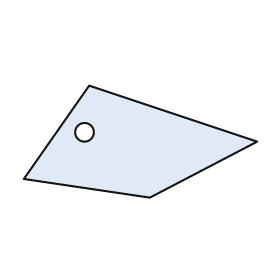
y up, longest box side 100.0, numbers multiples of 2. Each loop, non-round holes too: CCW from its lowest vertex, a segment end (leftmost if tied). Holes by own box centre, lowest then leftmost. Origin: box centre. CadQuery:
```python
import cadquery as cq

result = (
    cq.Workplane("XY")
    .moveTo(4.0, -24.0)
    .lineTo(50.0, 0.0)
    .lineTo(-22.0, 24.0)
    .lineTo(-50.0, -16.0)
    .close()
    .moveTo(-24.0, 4.0)
    .circle(4.0)
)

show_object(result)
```